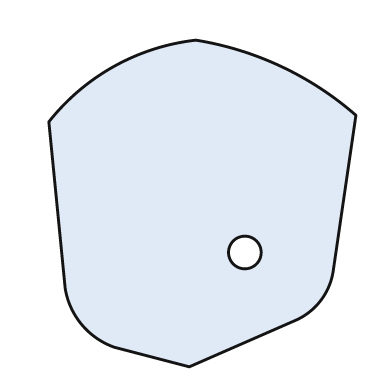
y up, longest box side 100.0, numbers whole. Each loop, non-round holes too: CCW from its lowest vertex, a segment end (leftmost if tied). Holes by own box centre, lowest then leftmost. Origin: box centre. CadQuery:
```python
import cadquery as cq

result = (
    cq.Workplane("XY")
    .moveTo(-4.0, -50.0)
    .lineTo(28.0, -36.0)
    .threePointArc((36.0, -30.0), (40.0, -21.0))
    .lineTo(47.0, 27.0)
    .threePointArc((24.0, 42.0), (-2.0, 50.0))
    .threePointArc((-27.0, 42.0), (-47.0, 25.0))
    .lineTo(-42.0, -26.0)
    .threePointArc((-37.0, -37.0), (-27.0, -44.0))
    .close()
    .moveTo(13.0, -15.0)
    .circle(5.0)
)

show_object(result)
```